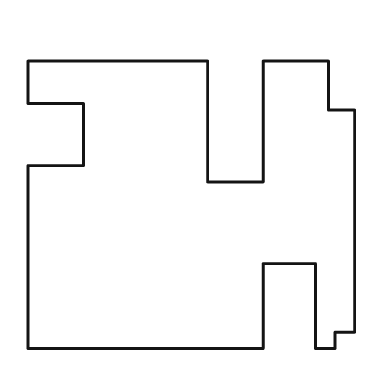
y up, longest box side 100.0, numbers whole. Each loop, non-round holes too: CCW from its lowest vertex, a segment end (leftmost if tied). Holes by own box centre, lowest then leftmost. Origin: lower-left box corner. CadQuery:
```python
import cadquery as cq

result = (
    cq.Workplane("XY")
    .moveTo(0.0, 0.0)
    .lineTo(72.0, 0.0)
    .lineTo(72.0, 26.0)
    .lineTo(88.0, 26.0)
    .lineTo(88.0, 0.0)
    .lineTo(94.0, 0.0)
    .lineTo(94.0, 5.0)
    .lineTo(100.0, 5.0)
    .lineTo(100.0, 73.0)
    .lineTo(92.0, 73.0)
    .lineTo(92.0, 88.0)
    .lineTo(72.0, 88.0)
    .lineTo(72.0, 51.0)
    .lineTo(55.0, 51.0)
    .lineTo(55.0, 88.0)
    .lineTo(0.0, 88.0)
    .lineTo(0.0, 75.0)
    .lineTo(17.0, 75.0)
    .lineTo(17.0, 56.0)
    .lineTo(0.0, 56.0)
    .close()
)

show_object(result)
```